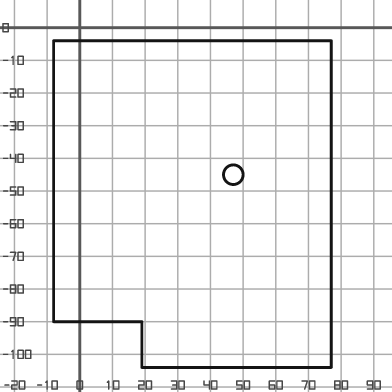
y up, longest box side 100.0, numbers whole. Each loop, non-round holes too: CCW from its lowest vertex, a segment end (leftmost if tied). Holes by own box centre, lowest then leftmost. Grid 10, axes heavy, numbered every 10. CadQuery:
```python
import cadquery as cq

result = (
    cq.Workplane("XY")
    .moveTo(19.0, -104.0)
    .lineTo(77.0, -104.0)
    .lineTo(77.0, -4.0)
    .lineTo(-8.0, -4.0)
    .lineTo(-8.0, -90.0)
    .lineTo(19.0, -90.0)
    .close()
    .moveTo(47.0, -45.0)
    .circle(3.0)
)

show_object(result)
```